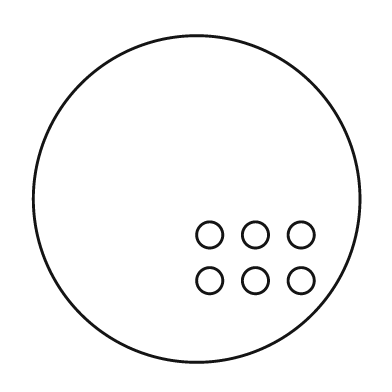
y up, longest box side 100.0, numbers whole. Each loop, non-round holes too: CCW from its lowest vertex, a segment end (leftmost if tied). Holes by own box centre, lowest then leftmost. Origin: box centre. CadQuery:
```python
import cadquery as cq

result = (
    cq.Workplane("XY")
    .moveTo(0.0, 0.0)
    .circle(50.0)
    .moveTo(4.0, -25.0)
    .circle(4.0)
    .moveTo(18.0, -25.0)
    .circle(4.0)
    .moveTo(32.0, -25.0)
    .circle(4.0)
    .moveTo(4.0, -11.0)
    .circle(4.0)
    .moveTo(18.0, -11.0)
    .circle(4.0)
    .moveTo(32.0, -11.0)
    .circle(4.0)
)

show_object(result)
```